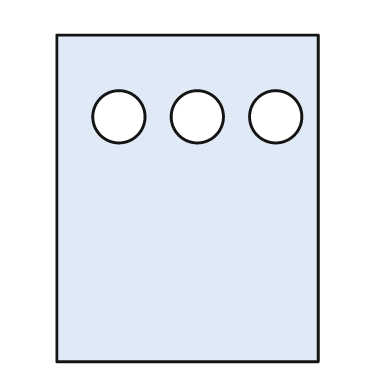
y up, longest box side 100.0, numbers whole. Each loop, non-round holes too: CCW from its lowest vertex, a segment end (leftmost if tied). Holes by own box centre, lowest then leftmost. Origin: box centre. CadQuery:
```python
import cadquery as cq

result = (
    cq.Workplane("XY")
    .moveTo(-40.0, -50.0)
    .lineTo(40.0, -50.0)
    .lineTo(40.0, 50.0)
    .lineTo(-40.0, 50.0)
    .close()
    .moveTo(-21.0, 25.0)
    .circle(8.0)
    .moveTo(3.0, 25.0)
    .circle(8.0)
    .moveTo(27.0, 25.0)
    .circle(8.0)
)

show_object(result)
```